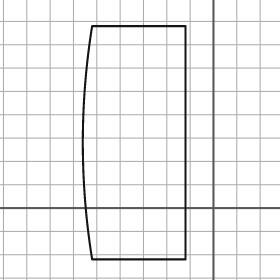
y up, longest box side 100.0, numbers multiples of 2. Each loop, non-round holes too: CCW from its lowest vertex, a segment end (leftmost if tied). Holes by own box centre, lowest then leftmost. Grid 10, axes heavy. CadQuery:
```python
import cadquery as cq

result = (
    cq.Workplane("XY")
    .moveTo(-52.0, -22.0)
    .lineTo(-12.0, -22.0)
    .lineTo(-12.0, 78.0)
    .lineTo(-52.0, 78.0)
    .threePointArc((-56.0, 28.0), (-52.0, -22.0))
    .close()
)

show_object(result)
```